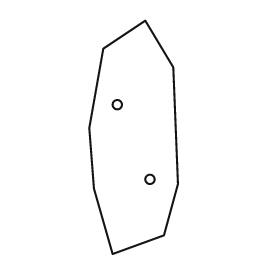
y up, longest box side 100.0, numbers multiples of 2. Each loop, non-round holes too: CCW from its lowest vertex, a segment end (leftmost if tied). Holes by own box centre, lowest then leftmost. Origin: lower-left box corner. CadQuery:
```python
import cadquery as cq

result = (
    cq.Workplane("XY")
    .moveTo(10.0, 0.0)
    .lineTo(32.0, 8.0)
    .lineTo(38.0, 30.0)
    .lineTo(36.0, 80.0)
    .lineTo(24.0, 100.0)
    .lineTo(6.0, 88.0)
    .lineTo(0.0, 54.0)
    .lineTo(2.0, 28.0)
    .close()
    .moveTo(26.0, 32.0)
    .circle(2.0)
    .moveTo(12.0, 64.0)
    .circle(2.0)
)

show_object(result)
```